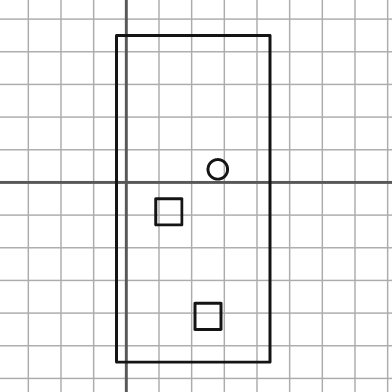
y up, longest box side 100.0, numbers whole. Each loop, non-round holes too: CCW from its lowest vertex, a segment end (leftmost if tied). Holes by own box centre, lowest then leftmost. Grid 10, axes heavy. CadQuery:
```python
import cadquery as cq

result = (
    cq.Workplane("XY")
    .moveTo(-3.0, -55.0)
    .lineTo(44.0, -55.0)
    .lineTo(44.0, 45.0)
    .lineTo(-3.0, 45.0)
    .close()
    .moveTo(21.0, -45.0)
    .lineTo(29.0, -45.0)
    .lineTo(29.0, -37.0)
    .lineTo(21.0, -37.0)
    .close()
    .moveTo(9.0, -13.0)
    .lineTo(17.0, -13.0)
    .lineTo(17.0, -5.0)
    .lineTo(9.0, -5.0)
    .close()
    .moveTo(28.0, 4.0)
    .circle(3.0)
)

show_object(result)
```